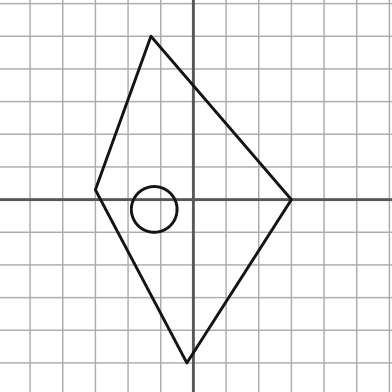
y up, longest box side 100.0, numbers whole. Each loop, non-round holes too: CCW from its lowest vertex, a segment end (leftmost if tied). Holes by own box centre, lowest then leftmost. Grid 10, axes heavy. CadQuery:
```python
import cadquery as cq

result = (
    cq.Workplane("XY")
    .moveTo(-2.0, -50.0)
    .lineTo(30.0, 0.0)
    .lineTo(-13.0, 50.0)
    .lineTo(-30.0, 3.0)
    .close()
    .moveTo(-12.0, -3.0)
    .circle(7.0)
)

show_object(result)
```